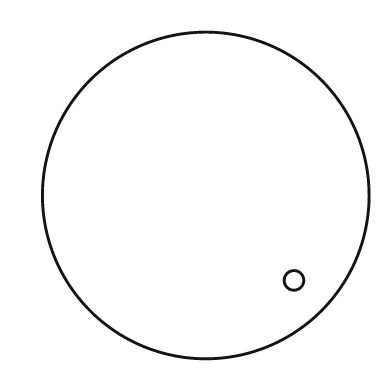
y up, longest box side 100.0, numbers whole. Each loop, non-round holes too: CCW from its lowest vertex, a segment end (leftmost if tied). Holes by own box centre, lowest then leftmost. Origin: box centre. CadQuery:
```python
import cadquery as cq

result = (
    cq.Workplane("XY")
    .moveTo(0.0, 0.0)
    .circle(50.0)
    .moveTo(27.0, -26.0)
    .circle(3.0)
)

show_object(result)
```